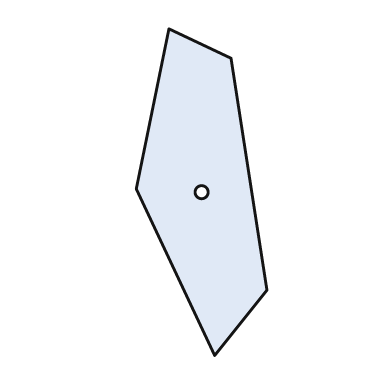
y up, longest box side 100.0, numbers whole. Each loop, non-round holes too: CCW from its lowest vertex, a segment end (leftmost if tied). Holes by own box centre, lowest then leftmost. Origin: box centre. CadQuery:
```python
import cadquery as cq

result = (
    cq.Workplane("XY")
    .moveTo(4.0, -50.0)
    .lineTo(20.0, -30.0)
    .lineTo(9.0, 41.0)
    .lineTo(-10.0, 50.0)
    .lineTo(-20.0, 1.0)
    .close()
    .moveTo(0.0, 0.0)
    .circle(2.0)
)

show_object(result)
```